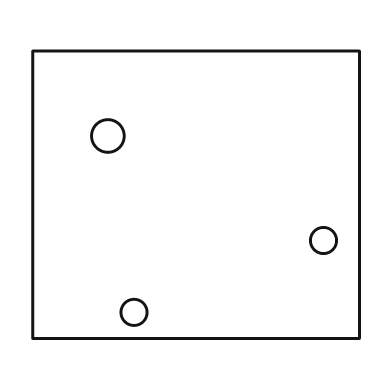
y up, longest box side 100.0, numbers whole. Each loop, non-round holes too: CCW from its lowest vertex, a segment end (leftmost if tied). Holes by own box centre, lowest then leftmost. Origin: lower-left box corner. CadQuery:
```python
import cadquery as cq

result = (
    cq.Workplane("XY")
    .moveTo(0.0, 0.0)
    .lineTo(100.0, 0.0)
    .lineTo(100.0, 88.0)
    .lineTo(0.0, 88.0)
    .close()
    .moveTo(31.0, 8.0)
    .circle(4.0)
    .moveTo(89.0, 30.0)
    .circle(4.0)
    .moveTo(23.0, 62.0)
    .circle(5.0)
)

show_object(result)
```